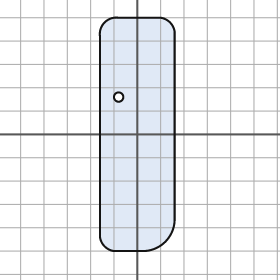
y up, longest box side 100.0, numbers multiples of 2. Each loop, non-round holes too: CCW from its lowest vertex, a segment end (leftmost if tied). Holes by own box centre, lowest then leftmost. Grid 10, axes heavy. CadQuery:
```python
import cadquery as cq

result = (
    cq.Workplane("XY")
    .moveTo(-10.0, -50.0)
    .lineTo(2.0, -50.0)
    .threePointArc((12.0, -46.0), (16.0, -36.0))
    .lineTo(16.0, 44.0)
    .threePointArc((14.0, 48.0), (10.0, 50.0))
    .lineTo(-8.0, 50.0)
    .threePointArc((-14.0, 48.0), (-16.0, 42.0))
    .lineTo(-16.0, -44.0)
    .threePointArc((-14.0, -48.0), (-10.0, -50.0))
    .close()
    .moveTo(-8.0, 16.0)
    .circle(2.0)
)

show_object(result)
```